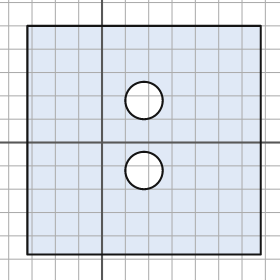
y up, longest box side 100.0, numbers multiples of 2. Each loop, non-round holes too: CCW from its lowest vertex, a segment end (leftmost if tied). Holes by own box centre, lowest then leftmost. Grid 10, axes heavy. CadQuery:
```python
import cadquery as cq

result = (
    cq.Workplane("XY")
    .moveTo(-32.0, -48.0)
    .lineTo(68.0, -48.0)
    .lineTo(68.0, 50.0)
    .lineTo(-32.0, 50.0)
    .close()
    .moveTo(18.0, -12.0)
    .circle(8.0)
    .moveTo(18.0, 18.0)
    .circle(8.0)
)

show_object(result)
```